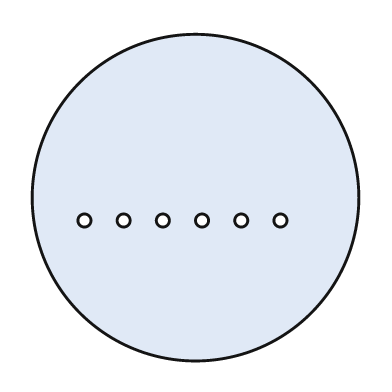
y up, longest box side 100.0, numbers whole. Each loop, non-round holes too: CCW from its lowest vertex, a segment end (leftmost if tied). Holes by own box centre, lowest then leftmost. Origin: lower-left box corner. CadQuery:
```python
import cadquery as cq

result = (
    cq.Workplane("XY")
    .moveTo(50.0, 50.0)
    .circle(50.0)
    .moveTo(16.0, 43.0)
    .circle(2.0)
    .moveTo(28.0, 43.0)
    .circle(2.0)
    .moveTo(40.0, 43.0)
    .circle(2.0)
    .moveTo(52.0, 43.0)
    .circle(2.0)
    .moveTo(64.0, 43.0)
    .circle(2.0)
    .moveTo(76.0, 43.0)
    .circle(2.0)
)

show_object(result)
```